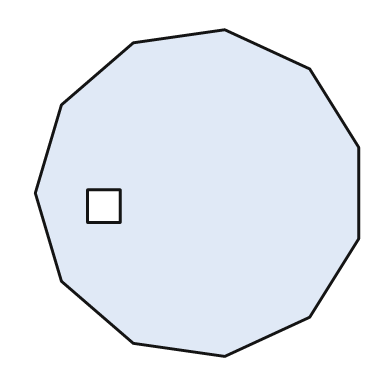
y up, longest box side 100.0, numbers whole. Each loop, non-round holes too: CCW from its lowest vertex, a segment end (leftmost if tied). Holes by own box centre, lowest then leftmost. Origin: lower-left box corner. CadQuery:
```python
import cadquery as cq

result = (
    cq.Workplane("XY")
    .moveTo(58.0, 0.0)
    .lineTo(84.0, 12.0)
    .lineTo(99.0, 36.0)
    .lineTo(99.0, 64.0)
    .lineTo(84.0, 88.0)
    .lineTo(58.0, 100.0)
    .lineTo(30.0, 96.0)
    .lineTo(8.0, 77.0)
    .lineTo(0.0, 50.0)
    .lineTo(8.0, 23.0)
    .lineTo(30.0, 4.0)
    .close()
    .moveTo(16.0, 41.0)
    .lineTo(26.0, 41.0)
    .lineTo(26.0, 51.0)
    .lineTo(16.0, 51.0)
    .close()
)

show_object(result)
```